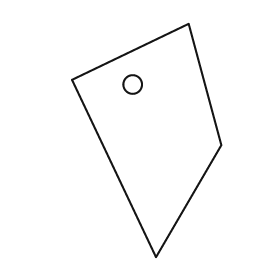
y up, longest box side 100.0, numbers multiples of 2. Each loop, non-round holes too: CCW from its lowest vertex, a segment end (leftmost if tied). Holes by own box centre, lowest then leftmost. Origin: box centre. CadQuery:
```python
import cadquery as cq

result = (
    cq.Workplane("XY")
    .moveTo(4.0, -50.0)
    .lineTo(32.0, -2.0)
    .lineTo(18.0, 50.0)
    .lineTo(-32.0, 26.0)
    .close()
    .moveTo(-6.0, 24.0)
    .circle(4.0)
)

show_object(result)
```